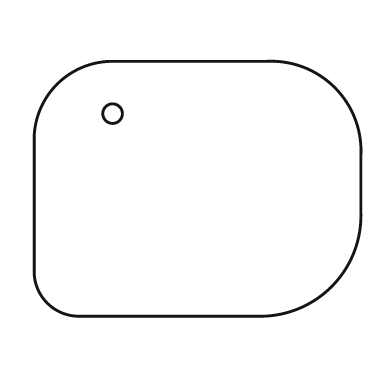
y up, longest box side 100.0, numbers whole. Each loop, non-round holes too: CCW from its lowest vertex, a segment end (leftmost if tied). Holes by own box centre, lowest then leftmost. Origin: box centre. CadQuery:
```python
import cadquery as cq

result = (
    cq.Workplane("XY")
    .moveTo(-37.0, -39.0)
    .lineTo(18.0, -39.0)
    .threePointArc((41.0, -30.0), (50.0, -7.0))
    .lineTo(50.0, 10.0)
    .threePointArc((42.0, 31.0), (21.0, 39.0))
    .lineTo(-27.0, 39.0)
    .threePointArc((-43.0, 32.0), (-50.0, 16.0))
    .lineTo(-50.0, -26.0)
    .threePointArc((-46.0, -35.0), (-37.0, -39.0))
    .close()
    .moveTo(-26.0, 23.0)
    .circle(3.0)
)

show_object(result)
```